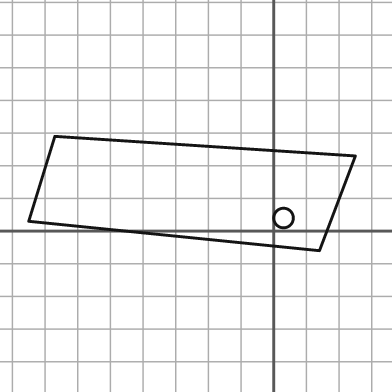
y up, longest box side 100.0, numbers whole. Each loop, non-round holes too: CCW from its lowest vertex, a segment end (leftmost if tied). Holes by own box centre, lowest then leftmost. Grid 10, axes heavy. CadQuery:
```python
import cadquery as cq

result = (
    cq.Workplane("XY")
    .moveTo(14.0, -6.0)
    .lineTo(25.0, 23.0)
    .lineTo(-67.0, 29.0)
    .lineTo(-75.0, 3.0)
    .close()
    .moveTo(3.0, 4.0)
    .circle(3.0)
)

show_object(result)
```